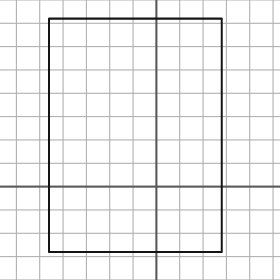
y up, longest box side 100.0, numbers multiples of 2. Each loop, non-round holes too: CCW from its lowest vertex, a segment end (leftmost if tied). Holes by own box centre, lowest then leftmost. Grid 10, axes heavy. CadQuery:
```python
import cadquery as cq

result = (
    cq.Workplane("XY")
    .moveTo(-46.0, -28.0)
    .lineTo(28.0, -28.0)
    .lineTo(28.0, 72.0)
    .lineTo(-46.0, 72.0)
    .close()
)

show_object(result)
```